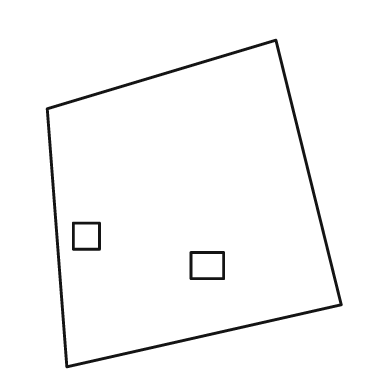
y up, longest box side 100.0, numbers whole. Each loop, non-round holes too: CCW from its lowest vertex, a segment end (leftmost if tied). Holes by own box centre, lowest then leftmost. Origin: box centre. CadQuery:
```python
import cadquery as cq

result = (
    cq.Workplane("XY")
    .moveTo(-39.0, -50.0)
    .lineTo(45.0, -31.0)
    .lineTo(25.0, 50.0)
    .lineTo(-45.0, 29.0)
    .close()
    .moveTo(-1.0, -23.0)
    .lineTo(9.0, -23.0)
    .lineTo(9.0, -15.0)
    .lineTo(-1.0, -15.0)
    .close()
    .moveTo(-37.0, -14.0)
    .lineTo(-29.0, -14.0)
    .lineTo(-29.0, -6.0)
    .lineTo(-37.0, -6.0)
    .close()
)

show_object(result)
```